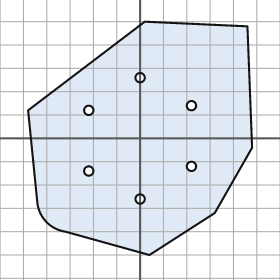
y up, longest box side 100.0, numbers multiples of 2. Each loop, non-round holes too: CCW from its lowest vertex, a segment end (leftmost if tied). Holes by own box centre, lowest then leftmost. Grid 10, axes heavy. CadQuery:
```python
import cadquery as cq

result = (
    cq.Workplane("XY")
    .moveTo(4.0, -50.0)
    .lineTo(32.0, -32.0)
    .lineTo(48.0, -4.0)
    .lineTo(46.0, 48.0)
    .lineTo(2.0, 50.0)
    .lineTo(-48.0, 12.0)
    .lineTo(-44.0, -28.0)
    .threePointArc((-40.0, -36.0), (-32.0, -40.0))
    .close()
    .moveTo(0.0, -26.0)
    .circle(2.0)
    .moveTo(-22.0, -14.0)
    .circle(2.0)
    .moveTo(22.0, -12.0)
    .circle(2.0)
    .moveTo(-22.0, 12.0)
    .circle(2.0)
    .moveTo(22.0, 14.0)
    .circle(2.0)
    .moveTo(0.0, 26.0)
    .circle(2.0)
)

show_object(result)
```